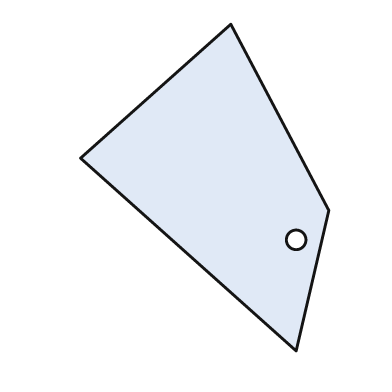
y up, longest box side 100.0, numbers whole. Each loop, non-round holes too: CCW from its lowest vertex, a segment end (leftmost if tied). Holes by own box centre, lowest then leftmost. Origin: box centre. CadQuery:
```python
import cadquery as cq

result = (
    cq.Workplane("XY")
    .moveTo(28.0, -50.0)
    .lineTo(38.0, -7.0)
    .lineTo(8.0, 50.0)
    .lineTo(-38.0, 9.0)
    .close()
    .moveTo(28.0, -16.0)
    .circle(3.0)
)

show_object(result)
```